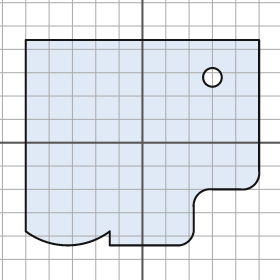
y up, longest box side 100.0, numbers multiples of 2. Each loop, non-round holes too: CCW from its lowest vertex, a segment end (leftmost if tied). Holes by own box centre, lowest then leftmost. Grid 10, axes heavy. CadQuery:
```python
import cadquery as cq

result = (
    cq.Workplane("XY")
    .moveTo(-14.0, -44.0)
    .lineTo(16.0, -44.0)
    .threePointArc((20.0, -42.0), (22.0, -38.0))
    .lineTo(22.0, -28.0)
    .threePointArc((24.0, -22.0), (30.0, -20.0))
    .lineTo(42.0, -20.0)
    .threePointArc((48.0, -18.0), (50.0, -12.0))
    .lineTo(50.0, 44.0)
    .lineTo(-50.0, 44.0)
    .lineTo(-50.0, -38.0)
    .threePointArc((-32.0, -44.0), (-14.0, -38.0))
    .close()
    .moveTo(30.0, 28.0)
    .circle(4.0)
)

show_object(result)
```